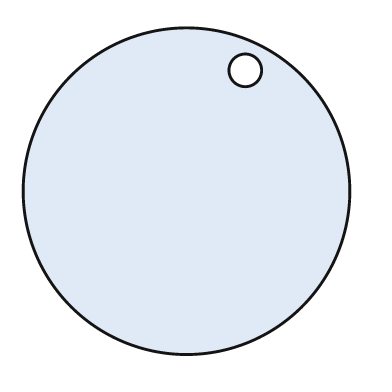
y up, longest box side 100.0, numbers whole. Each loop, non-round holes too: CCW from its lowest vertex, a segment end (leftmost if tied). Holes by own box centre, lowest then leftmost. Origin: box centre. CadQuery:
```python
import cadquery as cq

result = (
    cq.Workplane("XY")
    .moveTo(0.0, 0.0)
    .circle(50.0)
    .moveTo(18.0, 37.0)
    .circle(5.0)
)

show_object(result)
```